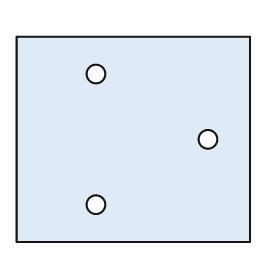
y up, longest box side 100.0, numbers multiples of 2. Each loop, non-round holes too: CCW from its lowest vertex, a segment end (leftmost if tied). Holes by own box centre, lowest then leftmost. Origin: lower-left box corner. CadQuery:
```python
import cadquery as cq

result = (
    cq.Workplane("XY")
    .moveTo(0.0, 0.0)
    .lineTo(100.0, 0.0)
    .lineTo(100.0, 88.0)
    .lineTo(0.0, 88.0)
    .close()
    .moveTo(34.0, 16.0)
    .circle(4.0)
    .moveTo(82.0, 44.0)
    .circle(4.0)
    .moveTo(34.0, 72.0)
    .circle(4.0)
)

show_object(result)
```